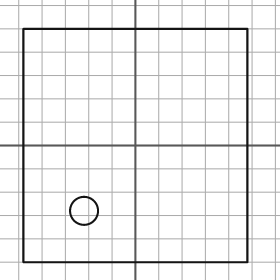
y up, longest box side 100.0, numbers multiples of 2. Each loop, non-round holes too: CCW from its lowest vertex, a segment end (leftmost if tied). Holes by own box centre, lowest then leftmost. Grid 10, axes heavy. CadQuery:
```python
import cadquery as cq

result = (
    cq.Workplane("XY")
    .moveTo(-48.0, -50.0)
    .lineTo(48.0, -50.0)
    .lineTo(48.0, 50.0)
    .lineTo(-48.0, 50.0)
    .close()
    .moveTo(-22.0, -28.0)
    .circle(6.0)
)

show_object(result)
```